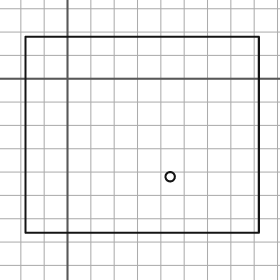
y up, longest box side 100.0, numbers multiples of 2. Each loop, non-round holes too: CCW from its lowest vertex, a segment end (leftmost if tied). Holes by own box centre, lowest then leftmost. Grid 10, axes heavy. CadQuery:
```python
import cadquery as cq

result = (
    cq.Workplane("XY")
    .moveTo(-18.0, -66.0)
    .lineTo(82.0, -66.0)
    .lineTo(82.0, 18.0)
    .lineTo(-18.0, 18.0)
    .close()
    .moveTo(44.0, -42.0)
    .circle(2.0)
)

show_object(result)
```